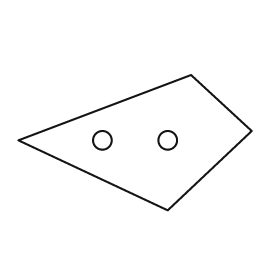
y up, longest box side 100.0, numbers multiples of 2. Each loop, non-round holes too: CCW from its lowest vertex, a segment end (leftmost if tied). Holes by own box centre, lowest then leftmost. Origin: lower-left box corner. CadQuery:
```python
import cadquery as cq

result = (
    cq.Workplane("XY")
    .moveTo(64.0, 0.0)
    .lineTo(100.0, 34.0)
    .lineTo(74.0, 58.0)
    .lineTo(0.0, 30.0)
    .close()
    .moveTo(36.0, 30.0)
    .circle(4.0)
    .moveTo(64.0, 30.0)
    .circle(4.0)
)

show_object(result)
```